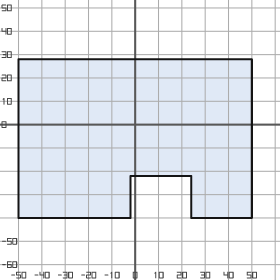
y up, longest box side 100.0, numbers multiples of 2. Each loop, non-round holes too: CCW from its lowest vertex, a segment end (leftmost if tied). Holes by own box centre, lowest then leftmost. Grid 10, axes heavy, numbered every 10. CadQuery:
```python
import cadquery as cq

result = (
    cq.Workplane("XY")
    .moveTo(-50.0, -40.0)
    .lineTo(-2.0, -40.0)
    .lineTo(-2.0, -22.0)
    .lineTo(24.0, -22.0)
    .lineTo(24.0, -40.0)
    .lineTo(50.0, -40.0)
    .lineTo(50.0, 28.0)
    .lineTo(-50.0, 28.0)
    .close()
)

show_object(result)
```